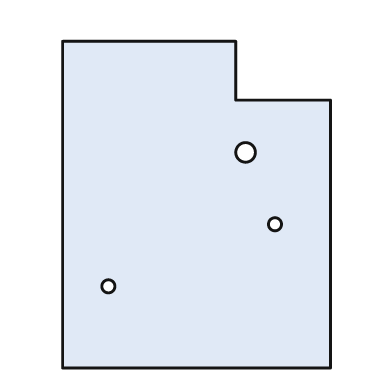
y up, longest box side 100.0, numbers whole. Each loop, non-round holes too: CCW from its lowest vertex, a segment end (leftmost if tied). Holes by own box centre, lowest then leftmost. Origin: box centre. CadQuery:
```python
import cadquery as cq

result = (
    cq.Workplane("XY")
    .moveTo(-41.0, -50.0)
    .lineTo(41.0, -50.0)
    .lineTo(41.0, 32.0)
    .lineTo(12.0, 32.0)
    .lineTo(12.0, 50.0)
    .lineTo(-41.0, 50.0)
    .close()
    .moveTo(-27.0, -25.0)
    .circle(2.0)
    .moveTo(24.0, -6.0)
    .circle(2.0)
    .moveTo(15.0, 16.0)
    .circle(3.0)
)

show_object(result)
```